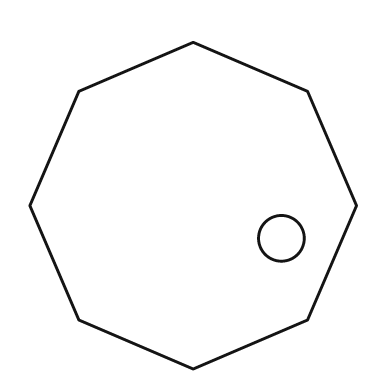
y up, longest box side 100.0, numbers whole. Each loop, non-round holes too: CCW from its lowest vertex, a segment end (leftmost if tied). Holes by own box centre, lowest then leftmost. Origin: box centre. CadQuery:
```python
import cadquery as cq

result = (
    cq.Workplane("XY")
    .moveTo(0.0, -50.0)
    .lineTo(35.0, -35.0)
    .lineTo(50.0, 0.0)
    .lineTo(35.0, 35.0)
    .lineTo(0.0, 50.0)
    .lineTo(-35.0, 35.0)
    .lineTo(-50.0, 0.0)
    .lineTo(-35.0, -35.0)
    .close()
    .moveTo(27.0, -10.0)
    .circle(7.0)
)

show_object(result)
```